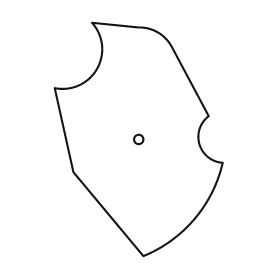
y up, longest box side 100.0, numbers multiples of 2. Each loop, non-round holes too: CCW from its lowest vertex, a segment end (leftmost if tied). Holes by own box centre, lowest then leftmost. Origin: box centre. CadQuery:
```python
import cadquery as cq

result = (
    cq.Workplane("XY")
    .moveTo(2.0, -50.0)
    .threePointArc((24.0, -34.0), (36.0, -10.0))
    .threePointArc((26.0, -2.0), (30.0, 10.0))
    .lineTo(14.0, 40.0)
    .threePointArc((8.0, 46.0), (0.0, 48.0))
    .lineTo(-20.0, 50.0)
    .threePointArc((-18.0, 30.0), (-36.0, 22.0))
    .lineTo(-28.0, -14.0)
    .close()
    .moveTo(0.0, 0.0)
    .circle(2.0)
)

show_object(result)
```